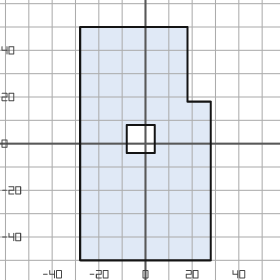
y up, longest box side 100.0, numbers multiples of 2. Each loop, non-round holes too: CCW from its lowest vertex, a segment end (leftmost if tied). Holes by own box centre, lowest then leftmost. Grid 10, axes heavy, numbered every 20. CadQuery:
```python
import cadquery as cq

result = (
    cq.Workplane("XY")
    .moveTo(-28.0, -50.0)
    .lineTo(28.0, -50.0)
    .lineTo(28.0, 18.0)
    .lineTo(18.0, 18.0)
    .lineTo(18.0, 50.0)
    .lineTo(-28.0, 50.0)
    .close()
    .moveTo(-8.0, -4.0)
    .lineTo(4.0, -4.0)
    .lineTo(4.0, 8.0)
    .lineTo(-8.0, 8.0)
    .close()
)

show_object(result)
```